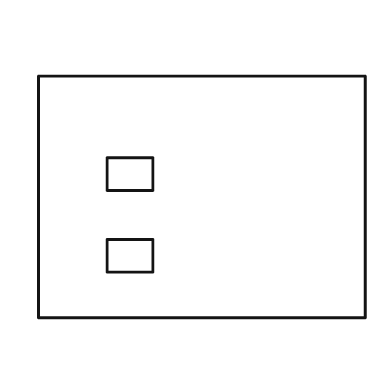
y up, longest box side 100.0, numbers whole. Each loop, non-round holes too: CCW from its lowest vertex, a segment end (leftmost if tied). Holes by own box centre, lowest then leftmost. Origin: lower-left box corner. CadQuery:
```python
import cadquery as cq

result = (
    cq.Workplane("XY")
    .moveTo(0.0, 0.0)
    .lineTo(100.0, 0.0)
    .lineTo(100.0, 74.0)
    .lineTo(0.0, 74.0)
    .close()
    .moveTo(21.0, 14.0)
    .lineTo(35.0, 14.0)
    .lineTo(35.0, 24.0)
    .lineTo(21.0, 24.0)
    .close()
    .moveTo(21.0, 39.0)
    .lineTo(35.0, 39.0)
    .lineTo(35.0, 49.0)
    .lineTo(21.0, 49.0)
    .close()
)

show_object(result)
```